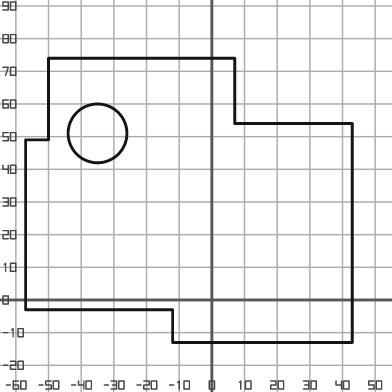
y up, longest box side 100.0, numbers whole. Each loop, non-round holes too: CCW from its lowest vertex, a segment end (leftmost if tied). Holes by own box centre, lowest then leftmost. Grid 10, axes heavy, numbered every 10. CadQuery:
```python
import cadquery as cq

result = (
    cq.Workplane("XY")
    .moveTo(-12.0, -13.0)
    .lineTo(43.0, -13.0)
    .lineTo(43.0, 54.0)
    .lineTo(7.0, 54.0)
    .lineTo(7.0, 74.0)
    .lineTo(-50.0, 74.0)
    .lineTo(-50.0, 49.0)
    .lineTo(-57.0, 49.0)
    .lineTo(-57.0, -3.0)
    .lineTo(-12.0, -3.0)
    .close()
    .moveTo(-35.0, 51.0)
    .circle(9.0)
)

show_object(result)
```